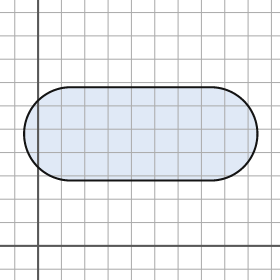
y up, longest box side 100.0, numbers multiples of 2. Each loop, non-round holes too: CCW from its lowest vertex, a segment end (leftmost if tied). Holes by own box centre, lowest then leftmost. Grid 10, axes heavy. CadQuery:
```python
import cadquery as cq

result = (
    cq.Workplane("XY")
    .moveTo(14.0, 28.0)
    .lineTo(74.0, 28.0)
    .threePointArc((94.0, 48.0), (74.0, 68.0))
    .lineTo(14.0, 68.0)
    .threePointArc((-6.0, 48.0), (14.0, 28.0))
    .close()
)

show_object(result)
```